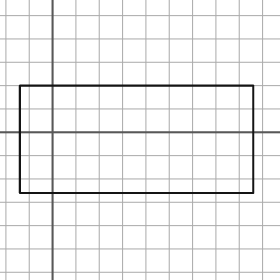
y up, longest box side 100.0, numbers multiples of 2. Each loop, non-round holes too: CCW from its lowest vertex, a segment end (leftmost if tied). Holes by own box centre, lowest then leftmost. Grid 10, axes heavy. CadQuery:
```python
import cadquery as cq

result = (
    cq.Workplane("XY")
    .moveTo(-14.0, -26.0)
    .lineTo(86.0, -26.0)
    .lineTo(86.0, 20.0)
    .lineTo(-14.0, 20.0)
    .close()
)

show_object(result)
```